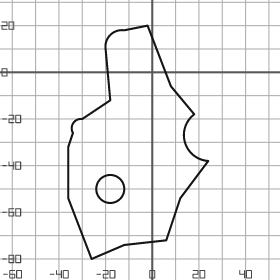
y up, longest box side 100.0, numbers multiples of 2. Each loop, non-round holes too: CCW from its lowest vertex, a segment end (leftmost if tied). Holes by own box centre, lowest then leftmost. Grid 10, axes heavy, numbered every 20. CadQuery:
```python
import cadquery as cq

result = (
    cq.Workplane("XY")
    .moveTo(-26.0, -80.0)
    .lineTo(-12.0, -74.0)
    .lineTo(6.0, -72.0)
    .lineTo(12.0, -54.0)
    .lineTo(24.0, -38.0)
    .threePointArc((14.0, -30.0), (18.0, -18.0))
    .lineTo(8.0, -6.0)
    .lineTo(-2.0, 20.0)
    .lineTo(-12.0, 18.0)
    .threePointArc((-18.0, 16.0), (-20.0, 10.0))
    .lineTo(-18.0, -12.0)
    .lineTo(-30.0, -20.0)
    .threePointArc((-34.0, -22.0), (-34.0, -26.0))
    .lineTo(-36.0, -32.0)
    .lineTo(-36.0, -54.0)
    .close()
    .moveTo(-18.0, -50.0)
    .circle(6.0)
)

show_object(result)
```